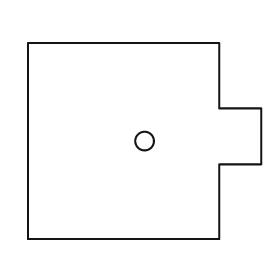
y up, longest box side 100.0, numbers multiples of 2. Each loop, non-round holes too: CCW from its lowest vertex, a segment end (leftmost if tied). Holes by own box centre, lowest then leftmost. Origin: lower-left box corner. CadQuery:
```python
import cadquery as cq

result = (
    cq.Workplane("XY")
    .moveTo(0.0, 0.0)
    .lineTo(82.0, 0.0)
    .lineTo(82.0, 32.0)
    .lineTo(100.0, 32.0)
    .lineTo(100.0, 56.0)
    .lineTo(82.0, 56.0)
    .lineTo(82.0, 84.0)
    .lineTo(0.0, 84.0)
    .close()
    .moveTo(50.0, 42.0)
    .circle(4.0)
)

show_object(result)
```